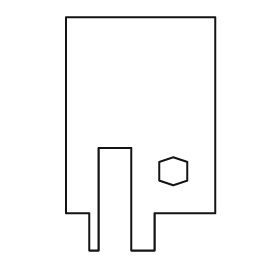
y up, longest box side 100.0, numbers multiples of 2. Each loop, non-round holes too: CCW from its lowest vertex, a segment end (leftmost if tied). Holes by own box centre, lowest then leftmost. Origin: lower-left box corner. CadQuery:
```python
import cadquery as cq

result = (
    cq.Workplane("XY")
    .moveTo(10.0, 0.0)
    .lineTo(14.0, 0.0)
    .lineTo(14.0, 44.0)
    .lineTo(28.0, 44.0)
    .lineTo(28.0, 0.0)
    .lineTo(38.0, 0.0)
    .lineTo(38.0, 16.0)
    .lineTo(64.0, 16.0)
    .lineTo(64.0, 100.0)
    .lineTo(0.0, 100.0)
    .lineTo(0.0, 16.0)
    .lineTo(10.0, 16.0)
    .close()
    .moveTo(46.0, 28.0)
    .lineTo(52.0, 30.0)
    .lineTo(52.0, 38.0)
    .lineTo(46.0, 40.0)
    .lineTo(40.0, 38.0)
    .lineTo(40.0, 30.0)
    .close()
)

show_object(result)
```